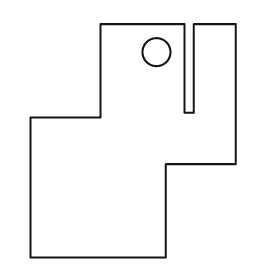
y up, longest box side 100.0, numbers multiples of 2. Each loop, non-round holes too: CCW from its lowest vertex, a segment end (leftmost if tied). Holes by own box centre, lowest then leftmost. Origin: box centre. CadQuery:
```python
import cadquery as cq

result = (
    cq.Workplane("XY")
    .moveTo(-44.0, -50.0)
    .lineTo(14.0, -50.0)
    .lineTo(14.0, -10.0)
    .lineTo(44.0, -10.0)
    .lineTo(44.0, 50.0)
    .lineTo(26.0, 50.0)
    .lineTo(26.0, 12.0)
    .lineTo(22.0, 12.0)
    .lineTo(22.0, 50.0)
    .lineTo(-14.0, 50.0)
    .lineTo(-14.0, 10.0)
    .lineTo(-44.0, 10.0)
    .close()
    .moveTo(10.0, 38.0)
    .circle(6.0)
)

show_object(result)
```